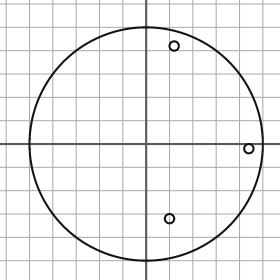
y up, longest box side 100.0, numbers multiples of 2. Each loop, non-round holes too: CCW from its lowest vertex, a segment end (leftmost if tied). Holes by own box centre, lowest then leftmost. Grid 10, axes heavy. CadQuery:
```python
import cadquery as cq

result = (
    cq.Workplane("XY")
    .moveTo(0.0, 0.0)
    .circle(50.0)
    .moveTo(10.0, -32.0)
    .circle(2.0)
    .moveTo(44.0, -2.0)
    .circle(2.0)
    .moveTo(12.0, 42.0)
    .circle(2.0)
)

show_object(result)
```